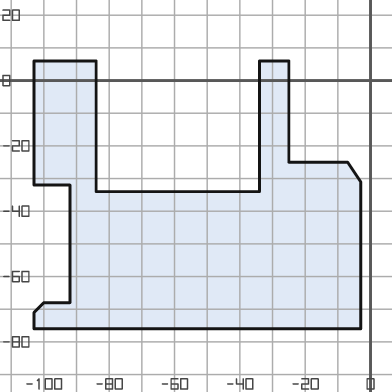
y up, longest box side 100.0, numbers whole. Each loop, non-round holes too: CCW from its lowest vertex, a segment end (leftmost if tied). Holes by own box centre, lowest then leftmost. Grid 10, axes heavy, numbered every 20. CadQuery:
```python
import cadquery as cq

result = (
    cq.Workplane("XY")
    .moveTo(-103.0, -76.0)
    .lineTo(-3.0, -76.0)
    .lineTo(-3.0, -31.0)
    .lineTo(-7.0, -25.0)
    .lineTo(-25.0, -25.0)
    .lineTo(-25.0, 6.0)
    .lineTo(-34.0, 6.0)
    .lineTo(-34.0, -34.0)
    .lineTo(-84.0, -34.0)
    .lineTo(-84.0, 6.0)
    .lineTo(-103.0, 6.0)
    .lineTo(-103.0, -32.0)
    .lineTo(-92.0, -32.0)
    .lineTo(-92.0, -68.0)
    .lineTo(-100.0, -68.0)
    .lineTo(-103.0, -71.0)
    .close()
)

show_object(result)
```